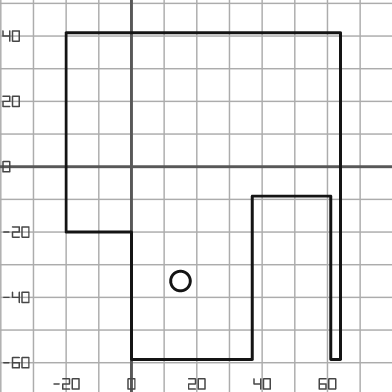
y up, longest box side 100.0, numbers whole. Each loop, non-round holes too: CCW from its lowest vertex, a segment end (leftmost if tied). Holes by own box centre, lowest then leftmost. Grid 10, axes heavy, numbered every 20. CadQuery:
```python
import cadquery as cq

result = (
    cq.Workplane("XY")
    .moveTo(0.0, -59.0)
    .lineTo(37.0, -59.0)
    .lineTo(37.0, -9.0)
    .lineTo(61.0, -9.0)
    .lineTo(61.0, -59.0)
    .lineTo(64.0, -59.0)
    .lineTo(64.0, 41.0)
    .lineTo(-20.0, 41.0)
    .lineTo(-20.0, -20.0)
    .lineTo(0.0, -20.0)
    .close()
    .moveTo(15.0, -35.0)
    .circle(3.0)
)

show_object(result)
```